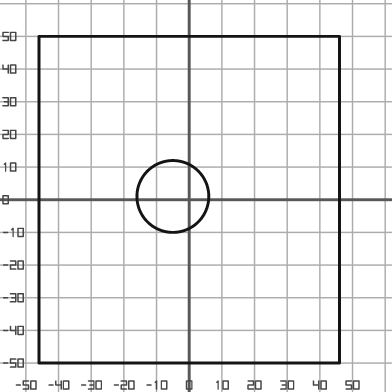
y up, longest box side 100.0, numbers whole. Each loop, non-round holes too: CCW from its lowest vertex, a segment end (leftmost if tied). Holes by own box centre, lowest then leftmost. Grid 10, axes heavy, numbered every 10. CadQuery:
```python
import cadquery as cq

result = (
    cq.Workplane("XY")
    .moveTo(-46.0, -50.0)
    .lineTo(46.0, -50.0)
    .lineTo(46.0, 50.0)
    .lineTo(-46.0, 50.0)
    .close()
    .moveTo(-5.0, 1.0)
    .circle(11.0)
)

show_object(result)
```